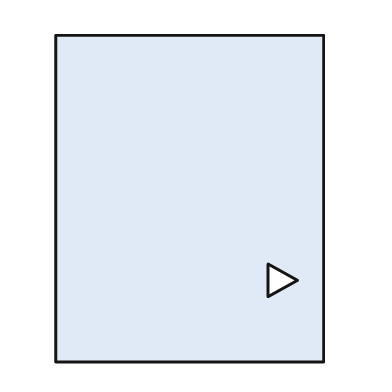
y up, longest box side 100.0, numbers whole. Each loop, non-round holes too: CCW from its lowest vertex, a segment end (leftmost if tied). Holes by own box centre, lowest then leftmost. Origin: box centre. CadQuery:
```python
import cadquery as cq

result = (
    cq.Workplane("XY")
    .moveTo(-41.0, -50.0)
    .lineTo(41.0, -50.0)
    .lineTo(41.0, 50.0)
    .lineTo(-41.0, 50.0)
    .close()
    .moveTo(24.0, -30.0)
    .lineTo(33.0, -25.0)
    .lineTo(24.0, -20.0)
    .close()
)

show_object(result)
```